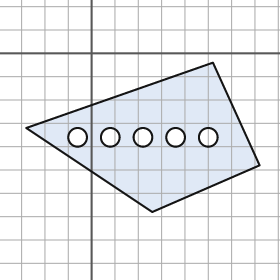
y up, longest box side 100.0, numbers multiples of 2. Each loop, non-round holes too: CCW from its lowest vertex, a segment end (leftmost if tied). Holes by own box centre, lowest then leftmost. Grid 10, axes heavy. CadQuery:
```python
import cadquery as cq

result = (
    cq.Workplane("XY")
    .moveTo(26.0, -68.0)
    .lineTo(72.0, -48.0)
    .lineTo(52.0, -4.0)
    .lineTo(-28.0, -32.0)
    .close()
    .moveTo(-6.0, -36.0)
    .circle(4.0)
    .moveTo(8.0, -36.0)
    .circle(4.0)
    .moveTo(22.0, -36.0)
    .circle(4.0)
    .moveTo(36.0, -36.0)
    .circle(4.0)
    .moveTo(50.0, -36.0)
    .circle(4.0)
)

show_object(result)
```